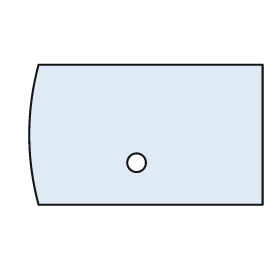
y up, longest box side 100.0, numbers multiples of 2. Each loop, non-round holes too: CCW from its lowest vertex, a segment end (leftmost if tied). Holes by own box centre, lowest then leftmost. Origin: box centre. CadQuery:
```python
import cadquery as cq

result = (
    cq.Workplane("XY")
    .moveTo(-46.0, -30.0)
    .lineTo(50.0, -30.0)
    .lineTo(50.0, 30.0)
    .lineTo(-46.0, 30.0)
    .threePointArc((-50.0, 0.0), (-46.0, -30.0))
    .close()
    .moveTo(-4.0, -12.0)
    .circle(4.0)
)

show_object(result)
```